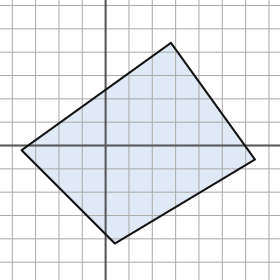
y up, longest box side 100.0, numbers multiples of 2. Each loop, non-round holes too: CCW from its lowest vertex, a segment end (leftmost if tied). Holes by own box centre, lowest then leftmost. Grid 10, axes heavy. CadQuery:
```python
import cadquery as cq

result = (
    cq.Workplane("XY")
    .moveTo(4.0, -42.0)
    .lineTo(64.0, -6.0)
    .lineTo(28.0, 44.0)
    .lineTo(-36.0, -2.0)
    .close()
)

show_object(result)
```